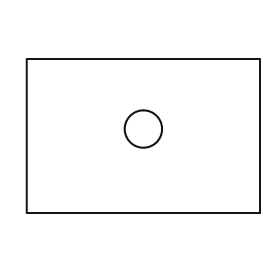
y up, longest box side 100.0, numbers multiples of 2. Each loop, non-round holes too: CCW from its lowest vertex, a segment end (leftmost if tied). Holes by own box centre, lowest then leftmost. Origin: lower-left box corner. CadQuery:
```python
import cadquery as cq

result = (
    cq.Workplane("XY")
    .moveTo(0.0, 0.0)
    .lineTo(100.0, 0.0)
    .lineTo(100.0, 66.0)
    .lineTo(0.0, 66.0)
    .close()
    .moveTo(50.0, 36.0)
    .circle(8.0)
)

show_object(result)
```